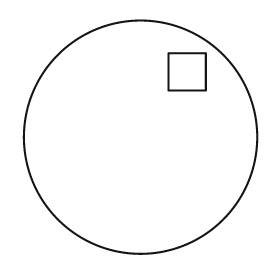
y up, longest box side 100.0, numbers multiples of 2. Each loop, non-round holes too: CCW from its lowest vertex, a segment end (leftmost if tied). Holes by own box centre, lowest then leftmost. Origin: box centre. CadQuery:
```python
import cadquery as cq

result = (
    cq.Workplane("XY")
    .moveTo(0.0, 0.0)
    .circle(50.0)
    .moveTo(12.0, 20.0)
    .lineTo(28.0, 20.0)
    .lineTo(28.0, 36.0)
    .lineTo(12.0, 36.0)
    .close()
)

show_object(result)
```